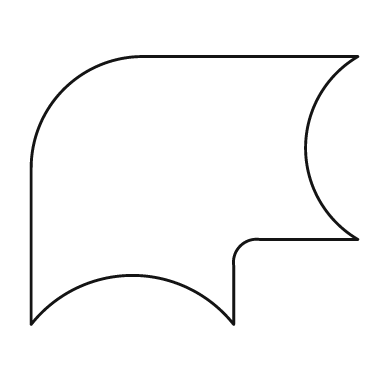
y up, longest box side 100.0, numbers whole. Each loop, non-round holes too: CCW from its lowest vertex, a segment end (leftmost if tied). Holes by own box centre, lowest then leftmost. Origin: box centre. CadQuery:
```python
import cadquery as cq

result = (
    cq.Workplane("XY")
    .moveTo(-50.0, -41.0)
    .threePointArc((-19.0, -26.0), (12.0, -41.0))
    .lineTo(12.0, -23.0)
    .threePointArc((14.0, -17.0), (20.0, -15.0))
    .lineTo(50.0, -15.0)
    .threePointArc((34.0, 13.0), (50.0, 41.0))
    .lineTo(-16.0, 41.0)
    .threePointArc((-40.0, 31.0), (-50.0, 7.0))
    .close()
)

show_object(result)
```